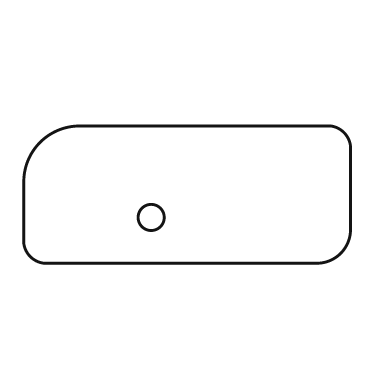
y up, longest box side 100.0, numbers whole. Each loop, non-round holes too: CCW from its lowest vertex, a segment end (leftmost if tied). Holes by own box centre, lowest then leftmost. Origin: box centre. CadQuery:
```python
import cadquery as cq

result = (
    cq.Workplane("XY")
    .moveTo(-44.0, -21.0)
    .lineTo(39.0, -21.0)
    .threePointArc((47.0, -18.0), (50.0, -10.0))
    .lineTo(50.0, 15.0)
    .threePointArc((48.0, 19.0), (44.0, 21.0))
    .lineTo(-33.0, 21.0)
    .threePointArc((-45.0, 16.0), (-50.0, 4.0))
    .lineTo(-50.0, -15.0)
    .threePointArc((-48.0, -19.0), (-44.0, -21.0))
    .close()
    .moveTo(-11.0, -7.0)
    .circle(4.0)
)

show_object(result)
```